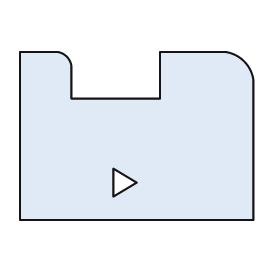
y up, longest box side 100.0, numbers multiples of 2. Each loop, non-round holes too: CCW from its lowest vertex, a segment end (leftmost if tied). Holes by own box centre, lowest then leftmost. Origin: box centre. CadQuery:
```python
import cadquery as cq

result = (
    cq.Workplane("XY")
    .moveTo(-50.0, -36.0)
    .lineTo(50.0, -36.0)
    .lineTo(50.0, 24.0)
    .threePointArc((46.0, 32.0), (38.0, 36.0))
    .lineTo(10.0, 36.0)
    .lineTo(10.0, 16.0)
    .lineTo(-28.0, 16.0)
    .lineTo(-28.0, 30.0)
    .threePointArc((-30.0, 34.0), (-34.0, 36.0))
    .lineTo(-50.0, 36.0)
    .close()
    .moveTo(-10.0, -26.0)
    .lineTo(0.0, -20.0)
    .lineTo(-10.0, -14.0)
    .close()
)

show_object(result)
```